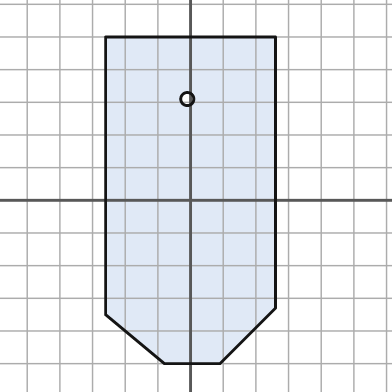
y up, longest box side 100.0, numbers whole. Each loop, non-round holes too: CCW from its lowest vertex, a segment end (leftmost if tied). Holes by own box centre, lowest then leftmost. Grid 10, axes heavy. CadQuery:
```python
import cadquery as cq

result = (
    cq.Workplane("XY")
    .moveTo(-8.0, -50.0)
    .lineTo(9.0, -50.0)
    .lineTo(26.0, -33.0)
    .lineTo(26.0, 50.0)
    .lineTo(-26.0, 50.0)
    .lineTo(-26.0, -35.0)
    .close()
    .moveTo(-1.0, 31.0)
    .circle(2.0)
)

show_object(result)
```